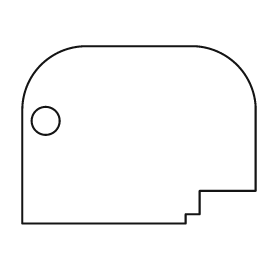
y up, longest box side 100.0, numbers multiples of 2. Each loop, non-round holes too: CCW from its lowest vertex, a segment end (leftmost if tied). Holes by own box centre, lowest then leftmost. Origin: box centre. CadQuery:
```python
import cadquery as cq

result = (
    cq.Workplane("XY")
    .moveTo(-50.0, -38.0)
    .lineTo(20.0, -38.0)
    .lineTo(20.0, -34.0)
    .lineTo(26.0, -34.0)
    .lineTo(26.0, -24.0)
    .lineTo(50.0, -24.0)
    .lineTo(50.0, 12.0)
    .threePointArc((42.0, 30.0), (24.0, 38.0))
    .lineTo(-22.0, 38.0)
    .threePointArc((-42.0, 30.0), (-50.0, 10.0))
    .close()
    .moveTo(-40.0, 6.0)
    .circle(6.0)
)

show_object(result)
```